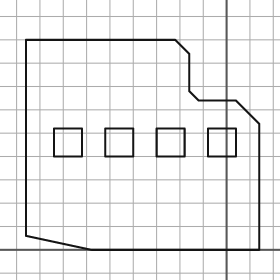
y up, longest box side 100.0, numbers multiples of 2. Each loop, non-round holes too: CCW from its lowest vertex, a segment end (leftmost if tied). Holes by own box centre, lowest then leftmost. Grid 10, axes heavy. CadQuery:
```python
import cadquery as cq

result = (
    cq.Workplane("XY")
    .moveTo(-58.0, 0.0)
    .lineTo(14.0, 0.0)
    .lineTo(14.0, 54.0)
    .lineTo(4.0, 64.0)
    .lineTo(-12.0, 64.0)
    .lineTo(-16.0, 68.0)
    .lineTo(-16.0, 84.0)
    .lineTo(-22.0, 90.0)
    .lineTo(-86.0, 90.0)
    .lineTo(-86.0, 6.0)
    .close()
    .moveTo(-74.0, 40.0)
    .lineTo(-62.0, 40.0)
    .lineTo(-62.0, 52.0)
    .lineTo(-74.0, 52.0)
    .close()
    .moveTo(-52.0, 40.0)
    .lineTo(-40.0, 40.0)
    .lineTo(-40.0, 52.0)
    .lineTo(-52.0, 52.0)
    .close()
    .moveTo(-30.0, 40.0)
    .lineTo(-18.0, 40.0)
    .lineTo(-18.0, 52.0)
    .lineTo(-30.0, 52.0)
    .close()
    .moveTo(-8.0, 40.0)
    .lineTo(4.0, 40.0)
    .lineTo(4.0, 52.0)
    .lineTo(-8.0, 52.0)
    .close()
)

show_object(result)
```